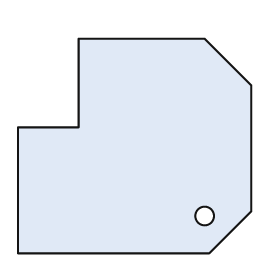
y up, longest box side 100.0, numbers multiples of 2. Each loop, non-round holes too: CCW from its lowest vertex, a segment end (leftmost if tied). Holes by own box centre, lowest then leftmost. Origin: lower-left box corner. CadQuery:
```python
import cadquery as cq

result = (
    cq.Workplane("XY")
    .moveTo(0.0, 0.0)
    .lineTo(82.0, 0.0)
    .lineTo(100.0, 18.0)
    .lineTo(100.0, 72.0)
    .lineTo(80.0, 92.0)
    .lineTo(26.0, 92.0)
    .lineTo(26.0, 54.0)
    .lineTo(0.0, 54.0)
    .close()
    .moveTo(80.0, 16.0)
    .circle(4.0)
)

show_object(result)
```